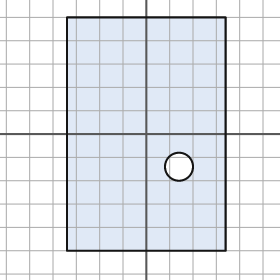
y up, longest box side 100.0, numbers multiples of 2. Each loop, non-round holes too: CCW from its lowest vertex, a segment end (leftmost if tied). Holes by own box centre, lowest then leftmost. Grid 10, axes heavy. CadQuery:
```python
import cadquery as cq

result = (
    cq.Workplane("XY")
    .moveTo(-34.0, -50.0)
    .lineTo(34.0, -50.0)
    .lineTo(34.0, 50.0)
    .lineTo(-34.0, 50.0)
    .close()
    .moveTo(14.0, -14.0)
    .circle(6.0)
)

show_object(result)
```